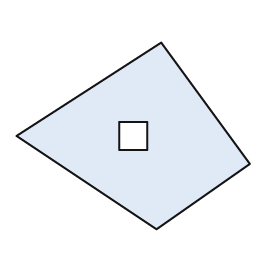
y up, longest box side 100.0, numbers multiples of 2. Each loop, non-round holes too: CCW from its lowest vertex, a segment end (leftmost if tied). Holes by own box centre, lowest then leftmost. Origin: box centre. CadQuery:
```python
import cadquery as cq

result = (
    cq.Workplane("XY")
    .moveTo(10.0, -40.0)
    .lineTo(50.0, -12.0)
    .lineTo(12.0, 40.0)
    .lineTo(-50.0, 0.0)
    .close()
    .moveTo(-6.0, -6.0)
    .lineTo(6.0, -6.0)
    .lineTo(6.0, 6.0)
    .lineTo(-6.0, 6.0)
    .close()
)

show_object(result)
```